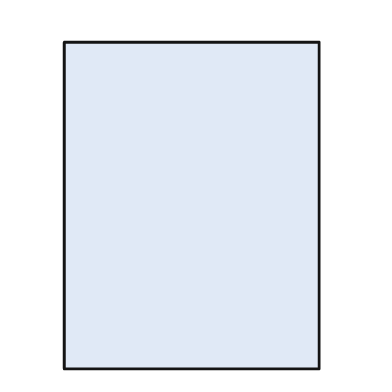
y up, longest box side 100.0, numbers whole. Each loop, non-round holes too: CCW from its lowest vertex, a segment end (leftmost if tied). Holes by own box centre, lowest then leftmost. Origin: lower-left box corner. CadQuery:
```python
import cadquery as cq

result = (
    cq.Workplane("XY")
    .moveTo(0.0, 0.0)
    .lineTo(78.0, 0.0)
    .lineTo(78.0, 100.0)
    .lineTo(0.0, 100.0)
    .close()
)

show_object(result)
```